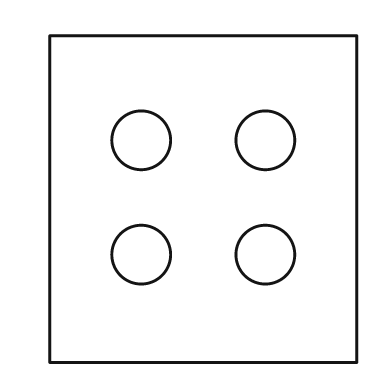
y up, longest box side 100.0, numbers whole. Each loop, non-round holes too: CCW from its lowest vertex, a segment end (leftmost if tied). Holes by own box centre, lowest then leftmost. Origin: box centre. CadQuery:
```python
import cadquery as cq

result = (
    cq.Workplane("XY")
    .moveTo(-47.0, -50.0)
    .lineTo(47.0, -50.0)
    .lineTo(47.0, 50.0)
    .lineTo(-47.0, 50.0)
    .close()
    .moveTo(-19.0, -17.0)
    .circle(9.0)
    .moveTo(19.0, -17.0)
    .circle(9.0)
    .moveTo(-19.0, 18.0)
    .circle(9.0)
    .moveTo(19.0, 18.0)
    .circle(9.0)
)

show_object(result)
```